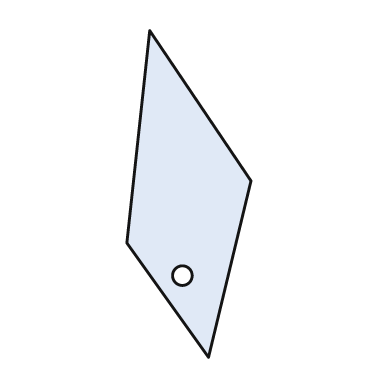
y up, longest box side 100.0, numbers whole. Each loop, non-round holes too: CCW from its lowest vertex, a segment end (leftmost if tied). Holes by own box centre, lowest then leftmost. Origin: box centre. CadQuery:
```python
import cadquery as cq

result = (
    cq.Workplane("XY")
    .moveTo(6.0, -50.0)
    .lineTo(19.0, 4.0)
    .lineTo(-12.0, 50.0)
    .lineTo(-19.0, -15.0)
    .close()
    .moveTo(-2.0, -25.0)
    .circle(3.0)
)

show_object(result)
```